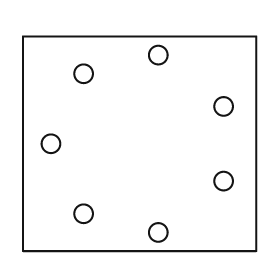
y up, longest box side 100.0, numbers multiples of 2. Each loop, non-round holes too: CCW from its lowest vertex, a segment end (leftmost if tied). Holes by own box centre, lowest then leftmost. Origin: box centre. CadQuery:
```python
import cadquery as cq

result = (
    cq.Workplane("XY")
    .moveTo(-50.0, -46.0)
    .lineTo(50.0, -46.0)
    .lineTo(50.0, 46.0)
    .lineTo(-50.0, 46.0)
    .close()
    .moveTo(8.0, -38.0)
    .circle(4.0)
    .moveTo(-24.0, -30.0)
    .circle(4.0)
    .moveTo(36.0, -16.0)
    .circle(4.0)
    .moveTo(-38.0, 0.0)
    .circle(4.0)
    .moveTo(36.0, 16.0)
    .circle(4.0)
    .moveTo(-24.0, 30.0)
    .circle(4.0)
    .moveTo(8.0, 38.0)
    .circle(4.0)
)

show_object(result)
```